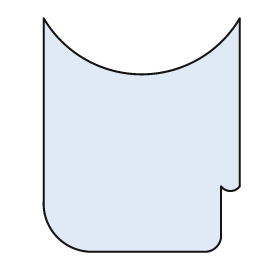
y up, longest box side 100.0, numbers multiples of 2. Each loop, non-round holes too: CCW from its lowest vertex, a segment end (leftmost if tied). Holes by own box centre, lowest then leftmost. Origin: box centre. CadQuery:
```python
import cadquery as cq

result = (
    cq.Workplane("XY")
    .moveTo(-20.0, -50.0)
    .lineTo(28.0, -50.0)
    .threePointArc((32.0, -48.0), (34.0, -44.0))
    .lineTo(34.0, -22.0)
    .threePointArc((38.0, -24.0), (42.0, -22.0))
    .lineTo(42.0, 50.0)
    .threePointArc((0.0, 26.0), (-42.0, 50.0))
    .lineTo(-42.0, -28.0)
    .threePointArc((-36.0, -44.0), (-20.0, -50.0))
    .close()
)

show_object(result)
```